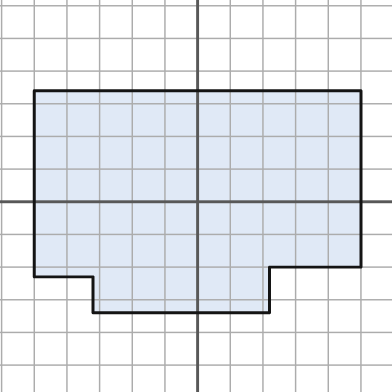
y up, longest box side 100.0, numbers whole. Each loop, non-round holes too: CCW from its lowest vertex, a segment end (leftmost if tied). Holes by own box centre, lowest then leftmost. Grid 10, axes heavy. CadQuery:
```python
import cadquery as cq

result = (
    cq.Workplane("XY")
    .moveTo(-32.0, -34.0)
    .lineTo(22.0, -34.0)
    .lineTo(22.0, -20.0)
    .lineTo(50.0, -20.0)
    .lineTo(50.0, 34.0)
    .lineTo(-50.0, 34.0)
    .lineTo(-50.0, -23.0)
    .lineTo(-32.0, -23.0)
    .close()
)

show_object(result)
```